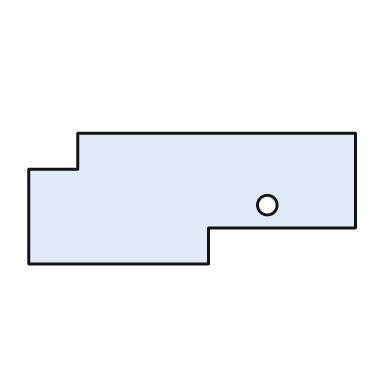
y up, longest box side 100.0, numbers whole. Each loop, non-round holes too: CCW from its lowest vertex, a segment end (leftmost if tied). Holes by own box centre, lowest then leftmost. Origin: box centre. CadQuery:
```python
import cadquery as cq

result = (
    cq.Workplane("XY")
    .moveTo(-50.0, -20.0)
    .lineTo(5.0, -20.0)
    .lineTo(5.0, -9.0)
    .lineTo(50.0, -9.0)
    .lineTo(50.0, 20.0)
    .lineTo(-35.0, 20.0)
    .lineTo(-35.0, 9.0)
    .lineTo(-50.0, 9.0)
    .close()
    .moveTo(23.0, -2.0)
    .circle(3.0)
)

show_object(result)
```